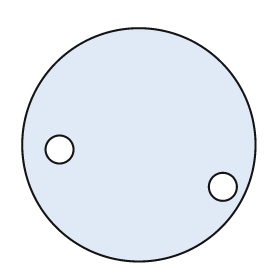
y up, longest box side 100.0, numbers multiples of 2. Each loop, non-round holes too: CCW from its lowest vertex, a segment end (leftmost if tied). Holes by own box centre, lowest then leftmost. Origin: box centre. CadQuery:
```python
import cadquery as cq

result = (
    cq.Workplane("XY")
    .moveTo(0.0, 0.0)
    .circle(50.0)
    .moveTo(36.0, -18.0)
    .circle(6.0)
    .moveTo(-34.0, -2.0)
    .circle(6.0)
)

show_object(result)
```